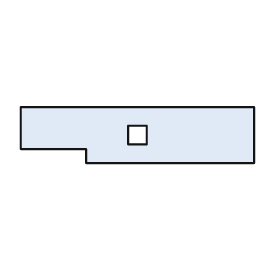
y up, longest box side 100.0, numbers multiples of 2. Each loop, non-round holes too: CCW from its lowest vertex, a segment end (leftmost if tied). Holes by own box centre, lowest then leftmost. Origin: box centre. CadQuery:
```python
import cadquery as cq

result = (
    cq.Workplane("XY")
    .moveTo(-22.0, -12.0)
    .lineTo(50.0, -12.0)
    .lineTo(50.0, 12.0)
    .lineTo(-50.0, 12.0)
    .lineTo(-50.0, -6.0)
    .lineTo(-22.0, -6.0)
    .close()
    .moveTo(-4.0, -4.0)
    .lineTo(4.0, -4.0)
    .lineTo(4.0, 4.0)
    .lineTo(-4.0, 4.0)
    .close()
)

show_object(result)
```